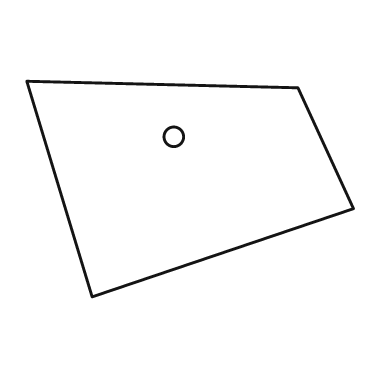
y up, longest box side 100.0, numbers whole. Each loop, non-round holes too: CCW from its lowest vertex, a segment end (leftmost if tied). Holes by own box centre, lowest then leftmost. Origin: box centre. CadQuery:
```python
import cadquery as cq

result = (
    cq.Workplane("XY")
    .moveTo(-30.0, -33.0)
    .lineTo(50.0, -6.0)
    .lineTo(33.0, 31.0)
    .lineTo(-50.0, 33.0)
    .close()
    .moveTo(-5.0, 16.0)
    .circle(3.0)
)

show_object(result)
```